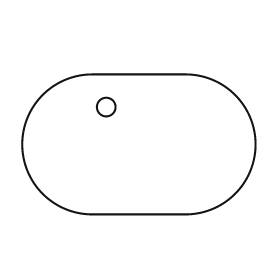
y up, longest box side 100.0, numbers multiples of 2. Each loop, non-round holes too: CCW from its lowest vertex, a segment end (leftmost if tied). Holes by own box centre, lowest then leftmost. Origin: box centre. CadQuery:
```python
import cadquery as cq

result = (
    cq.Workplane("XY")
    .moveTo(-20.0, -30.0)
    .lineTo(20.0, -30.0)
    .threePointArc((50.0, 0.0), (20.0, 30.0))
    .lineTo(-20.0, 30.0)
    .threePointArc((-50.0, 0.0), (-20.0, -30.0))
    .close()
    .moveTo(-14.0, 16.0)
    .circle(4.0)
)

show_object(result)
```